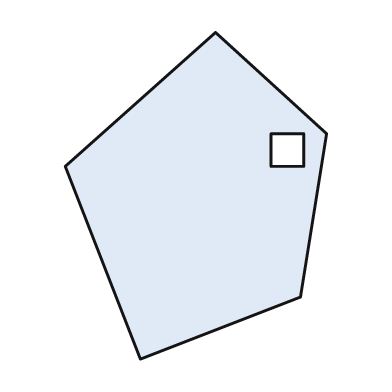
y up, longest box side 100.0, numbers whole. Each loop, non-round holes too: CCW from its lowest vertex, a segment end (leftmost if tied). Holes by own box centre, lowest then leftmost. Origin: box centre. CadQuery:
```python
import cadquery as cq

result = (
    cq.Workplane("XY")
    .moveTo(-17.0, -50.0)
    .lineTo(32.0, -31.0)
    .lineTo(40.0, 19.0)
    .lineTo(6.0, 50.0)
    .lineTo(-40.0, 9.0)
    .close()
    .moveTo(23.0, 9.0)
    .lineTo(33.0, 9.0)
    .lineTo(33.0, 19.0)
    .lineTo(23.0, 19.0)
    .close()
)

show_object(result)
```